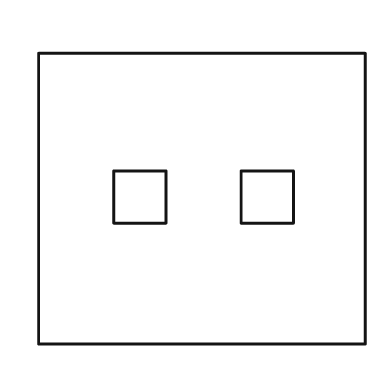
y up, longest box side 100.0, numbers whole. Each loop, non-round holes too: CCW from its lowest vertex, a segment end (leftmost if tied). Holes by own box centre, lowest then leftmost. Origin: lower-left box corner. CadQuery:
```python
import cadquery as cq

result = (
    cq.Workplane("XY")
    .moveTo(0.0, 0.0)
    .lineTo(100.0, 0.0)
    .lineTo(100.0, 89.0)
    .lineTo(0.0, 89.0)
    .close()
    .moveTo(23.0, 37.0)
    .lineTo(39.0, 37.0)
    .lineTo(39.0, 53.0)
    .lineTo(23.0, 53.0)
    .close()
    .moveTo(62.0, 37.0)
    .lineTo(78.0, 37.0)
    .lineTo(78.0, 53.0)
    .lineTo(62.0, 53.0)
    .close()
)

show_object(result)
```